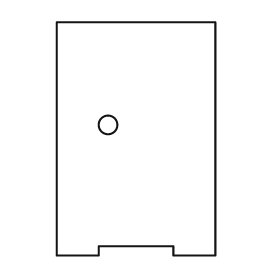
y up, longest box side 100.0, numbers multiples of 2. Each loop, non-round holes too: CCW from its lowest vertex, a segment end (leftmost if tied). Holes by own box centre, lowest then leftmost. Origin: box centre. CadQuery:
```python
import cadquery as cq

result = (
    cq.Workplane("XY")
    .moveTo(-34.0, -50.0)
    .lineTo(-16.0, -50.0)
    .lineTo(-16.0, -46.0)
    .lineTo(16.0, -46.0)
    .lineTo(16.0, -50.0)
    .lineTo(34.0, -50.0)
    .lineTo(34.0, 50.0)
    .lineTo(-34.0, 50.0)
    .close()
    .moveTo(-12.0, 6.0)
    .circle(4.0)
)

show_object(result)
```